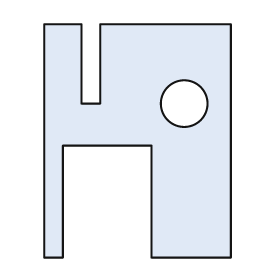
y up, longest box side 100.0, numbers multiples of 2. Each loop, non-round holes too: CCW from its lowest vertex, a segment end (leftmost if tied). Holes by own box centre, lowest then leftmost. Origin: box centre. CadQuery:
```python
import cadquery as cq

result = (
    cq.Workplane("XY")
    .moveTo(-40.0, -50.0)
    .lineTo(-32.0, -50.0)
    .lineTo(-32.0, -2.0)
    .lineTo(6.0, -2.0)
    .lineTo(6.0, -50.0)
    .lineTo(40.0, -50.0)
    .lineTo(40.0, 50.0)
    .lineTo(-16.0, 50.0)
    .lineTo(-16.0, 16.0)
    .lineTo(-24.0, 16.0)
    .lineTo(-24.0, 50.0)
    .lineTo(-40.0, 50.0)
    .close()
    .moveTo(20.0, 16.0)
    .circle(10.0)
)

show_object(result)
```